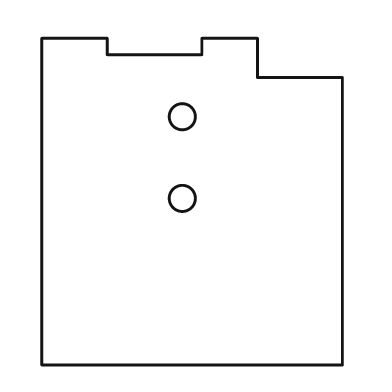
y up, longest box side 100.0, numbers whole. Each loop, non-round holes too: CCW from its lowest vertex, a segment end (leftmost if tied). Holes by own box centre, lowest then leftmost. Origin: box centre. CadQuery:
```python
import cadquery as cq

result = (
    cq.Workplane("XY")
    .moveTo(-46.0, -50.0)
    .lineTo(46.0, -50.0)
    .lineTo(46.0, 38.0)
    .lineTo(20.0, 38.0)
    .lineTo(20.0, 50.0)
    .lineTo(3.0, 50.0)
    .lineTo(3.0, 45.0)
    .lineTo(-26.0, 45.0)
    .lineTo(-26.0, 50.0)
    .lineTo(-46.0, 50.0)
    .close()
    .moveTo(-3.0, 1.0)
    .circle(4.0)
    .moveTo(-3.0, 26.0)
    .circle(4.0)
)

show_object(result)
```